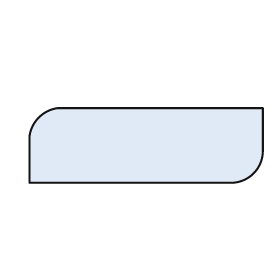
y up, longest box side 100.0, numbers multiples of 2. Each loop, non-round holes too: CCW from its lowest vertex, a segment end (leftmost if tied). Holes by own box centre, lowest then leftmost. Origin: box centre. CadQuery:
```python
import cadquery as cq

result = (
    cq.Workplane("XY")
    .moveTo(-50.0, -16.0)
    .lineTo(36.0, -16.0)
    .threePointArc((46.0, -12.0), (50.0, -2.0))
    .lineTo(50.0, 16.0)
    .lineTo(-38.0, 16.0)
    .threePointArc((-46.0, 12.0), (-50.0, 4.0))
    .close()
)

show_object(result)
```